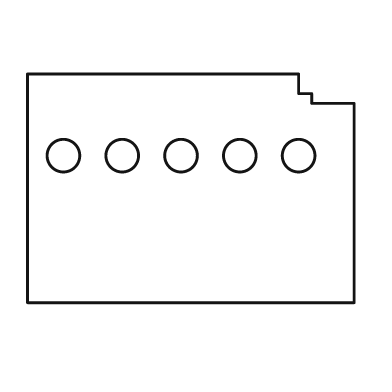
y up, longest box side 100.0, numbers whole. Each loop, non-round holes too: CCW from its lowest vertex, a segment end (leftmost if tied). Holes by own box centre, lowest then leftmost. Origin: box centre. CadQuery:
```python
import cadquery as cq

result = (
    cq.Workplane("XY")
    .moveTo(-50.0, -35.0)
    .lineTo(50.0, -35.0)
    .lineTo(50.0, 26.0)
    .lineTo(37.0, 26.0)
    .lineTo(37.0, 29.0)
    .lineTo(33.0, 29.0)
    .lineTo(33.0, 35.0)
    .lineTo(-50.0, 35.0)
    .close()
    .moveTo(-39.0, 10.0)
    .circle(5.0)
    .moveTo(-21.0, 10.0)
    .circle(5.0)
    .moveTo(-3.0, 10.0)
    .circle(5.0)
    .moveTo(15.0, 10.0)
    .circle(5.0)
    .moveTo(33.0, 10.0)
    .circle(5.0)
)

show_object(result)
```